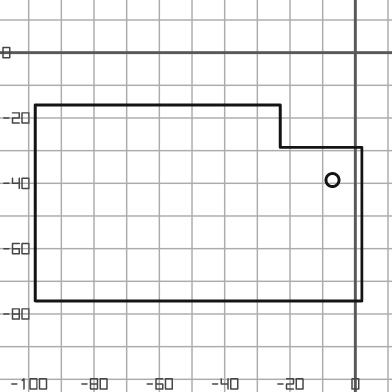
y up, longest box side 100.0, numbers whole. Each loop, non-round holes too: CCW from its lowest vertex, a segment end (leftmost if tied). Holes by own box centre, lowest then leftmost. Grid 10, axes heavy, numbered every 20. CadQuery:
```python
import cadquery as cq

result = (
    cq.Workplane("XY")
    .moveTo(-98.0, -76.0)
    .lineTo(2.0, -76.0)
    .lineTo(2.0, -29.0)
    .lineTo(-23.0, -29.0)
    .lineTo(-23.0, -16.0)
    .lineTo(-98.0, -16.0)
    .close()
    .moveTo(-7.0, -39.0)
    .circle(2.0)
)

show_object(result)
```